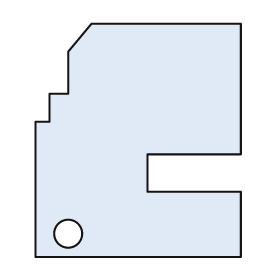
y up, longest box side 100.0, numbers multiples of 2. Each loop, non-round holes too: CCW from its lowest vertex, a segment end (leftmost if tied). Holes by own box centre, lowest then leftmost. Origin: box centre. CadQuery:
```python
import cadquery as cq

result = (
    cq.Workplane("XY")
    .moveTo(-44.0, -50.0)
    .lineTo(44.0, -50.0)
    .lineTo(44.0, -22.0)
    .lineTo(4.0, -22.0)
    .lineTo(4.0, -6.0)
    .lineTo(44.0, -6.0)
    .lineTo(44.0, 50.0)
    .lineTo(-20.0, 50.0)
    .lineTo(-30.0, 38.0)
    .lineTo(-30.0, 20.0)
    .lineTo(-38.0, 20.0)
    .lineTo(-38.0, 8.0)
    .lineTo(-44.0, 8.0)
    .close()
    .moveTo(-30.0, -40.0)
    .circle(6.0)
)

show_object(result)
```